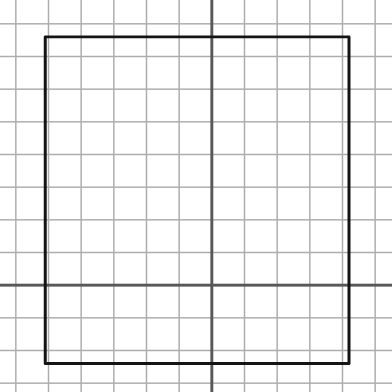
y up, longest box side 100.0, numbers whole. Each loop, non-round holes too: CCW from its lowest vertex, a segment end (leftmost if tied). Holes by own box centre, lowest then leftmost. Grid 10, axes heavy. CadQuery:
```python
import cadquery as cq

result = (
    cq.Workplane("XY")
    .moveTo(-51.0, -24.0)
    .lineTo(42.0, -24.0)
    .lineTo(42.0, 76.0)
    .lineTo(-51.0, 76.0)
    .close()
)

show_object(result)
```